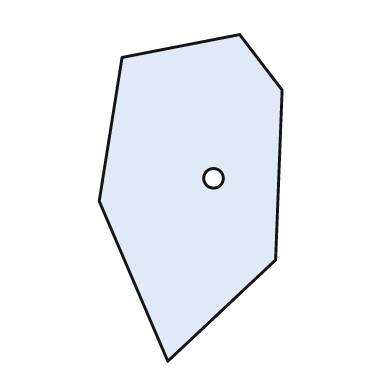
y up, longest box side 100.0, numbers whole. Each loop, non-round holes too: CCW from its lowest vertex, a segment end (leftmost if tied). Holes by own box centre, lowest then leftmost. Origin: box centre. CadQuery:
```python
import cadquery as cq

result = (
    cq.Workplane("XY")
    .moveTo(-7.0, -50.0)
    .lineTo(26.0, -19.0)
    .lineTo(28.0, 33.0)
    .lineTo(15.0, 50.0)
    .lineTo(-21.0, 43.0)
    .lineTo(-28.0, -1.0)
    .close()
    .moveTo(7.0, 6.0)
    .circle(3.0)
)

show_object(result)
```